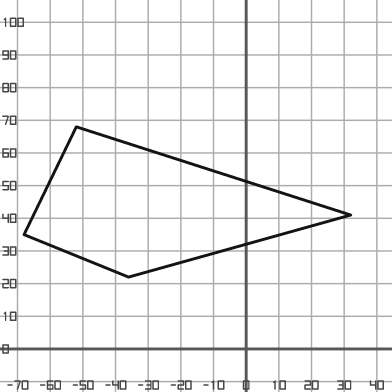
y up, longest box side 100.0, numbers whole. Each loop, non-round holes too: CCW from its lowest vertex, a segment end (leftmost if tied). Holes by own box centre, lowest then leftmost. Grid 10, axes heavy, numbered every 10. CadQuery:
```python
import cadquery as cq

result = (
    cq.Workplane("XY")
    .moveTo(-36.0, 22.0)
    .lineTo(32.0, 41.0)
    .lineTo(-52.0, 68.0)
    .lineTo(-68.0, 35.0)
    .close()
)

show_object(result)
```